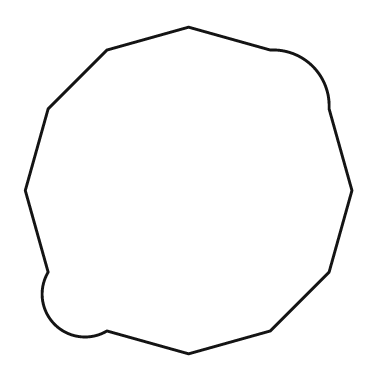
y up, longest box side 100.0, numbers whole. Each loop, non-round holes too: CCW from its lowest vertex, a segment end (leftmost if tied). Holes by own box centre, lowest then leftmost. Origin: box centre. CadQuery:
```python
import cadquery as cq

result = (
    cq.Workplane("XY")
    .moveTo(0.0, -50.0)
    .lineTo(25.0, -43.0)
    .lineTo(43.0, -25.0)
    .lineTo(50.0, 0.0)
    .lineTo(43.0, 25.0)
    .threePointArc((38.0, 38.0), (25.0, 43.0))
    .lineTo(0.0, 50.0)
    .lineTo(-25.0, 43.0)
    .lineTo(-43.0, 25.0)
    .lineTo(-50.0, 0.0)
    .lineTo(-43.0, -25.0)
    .threePointArc((-41.0, -41.0), (-25.0, -43.0))
    .close()
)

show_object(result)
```